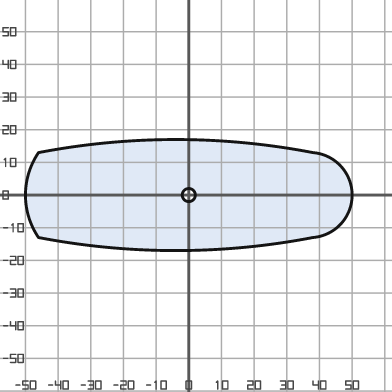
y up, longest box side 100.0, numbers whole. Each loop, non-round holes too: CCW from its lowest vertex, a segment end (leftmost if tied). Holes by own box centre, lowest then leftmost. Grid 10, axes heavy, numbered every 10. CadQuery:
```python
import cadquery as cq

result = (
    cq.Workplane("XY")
    .moveTo(-46.0, -13.0)
    .threePointArc((-4.0, -17.0), (38.0, -13.0))
    .threePointArc((50.0, 0.0), (38.0, 13.0))
    .threePointArc((-4.0, 17.0), (-46.0, 13.0))
    .threePointArc((-50.0, 0.0), (-46.0, -13.0))
    .close()
    .moveTo(0.0, 0.0)
    .circle(2.0)
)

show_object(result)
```